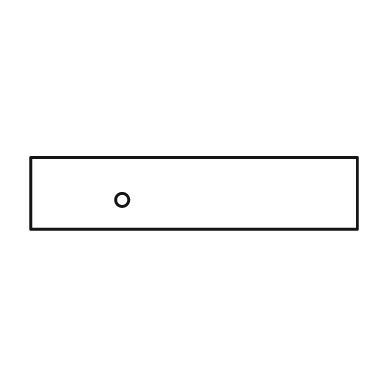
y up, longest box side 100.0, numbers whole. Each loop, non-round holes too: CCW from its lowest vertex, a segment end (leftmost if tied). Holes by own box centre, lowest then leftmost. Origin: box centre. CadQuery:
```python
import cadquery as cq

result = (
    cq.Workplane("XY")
    .moveTo(-50.0, -11.0)
    .lineTo(50.0, -11.0)
    .lineTo(50.0, 11.0)
    .lineTo(-50.0, 11.0)
    .close()
    .moveTo(-22.0, -2.0)
    .circle(2.0)
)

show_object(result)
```